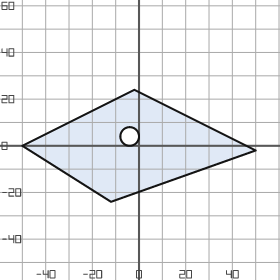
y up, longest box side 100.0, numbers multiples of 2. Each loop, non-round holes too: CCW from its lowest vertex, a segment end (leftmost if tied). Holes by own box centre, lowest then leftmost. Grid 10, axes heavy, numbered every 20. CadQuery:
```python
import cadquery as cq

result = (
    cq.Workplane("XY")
    .moveTo(-12.0, -24.0)
    .lineTo(50.0, -2.0)
    .lineTo(-2.0, 24.0)
    .lineTo(-50.0, 0.0)
    .close()
    .moveTo(-4.0, 4.0)
    .circle(4.0)
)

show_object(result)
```